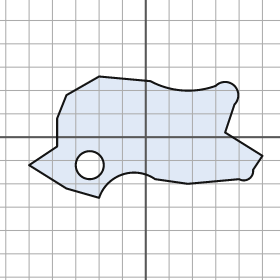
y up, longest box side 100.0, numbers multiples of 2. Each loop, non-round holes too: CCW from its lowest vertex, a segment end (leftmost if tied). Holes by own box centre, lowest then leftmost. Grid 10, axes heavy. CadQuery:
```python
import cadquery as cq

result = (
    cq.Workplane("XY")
    .moveTo(-20.0, -26.0)
    .threePointArc((-10.0, -16.0), (4.0, -18.0))
    .lineTo(18.0, -20.0)
    .lineTo(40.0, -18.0)
    .threePointArc((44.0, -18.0), (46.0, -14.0))
    .lineTo(50.0, -8.0)
    .lineTo(34.0, 2.0)
    .lineTo(38.0, 14.0)
    .threePointArc((38.0, 22.0), (30.0, 22.0))
    .threePointArc((16.0, 20.0), (2.0, 24.0))
    .lineTo(-20.0, 26.0)
    .lineTo(-34.0, 18.0)
    .lineTo(-38.0, 8.0)
    .lineTo(-38.0, -4.0)
    .lineTo(-50.0, -12.0)
    .lineTo(-34.0, -22.0)
    .close()
    .moveTo(-24.0, -12.0)
    .circle(6.0)
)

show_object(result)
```